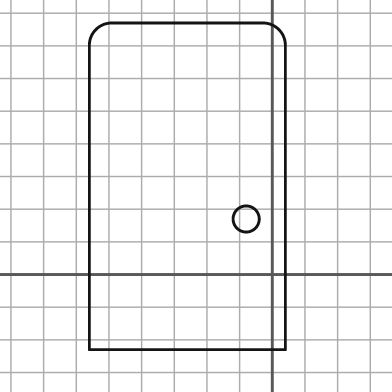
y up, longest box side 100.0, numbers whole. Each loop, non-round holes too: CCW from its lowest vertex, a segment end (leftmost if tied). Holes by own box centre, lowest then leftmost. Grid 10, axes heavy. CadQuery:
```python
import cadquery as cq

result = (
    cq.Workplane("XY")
    .moveTo(-56.0, -23.0)
    .lineTo(4.0, -23.0)
    .lineTo(4.0, 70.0)
    .threePointArc((2.0, 75.0), (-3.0, 77.0))
    .lineTo(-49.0, 77.0)
    .threePointArc((-54.0, 75.0), (-56.0, 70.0))
    .close()
    .moveTo(-8.0, 17.0)
    .circle(4.0)
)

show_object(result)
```